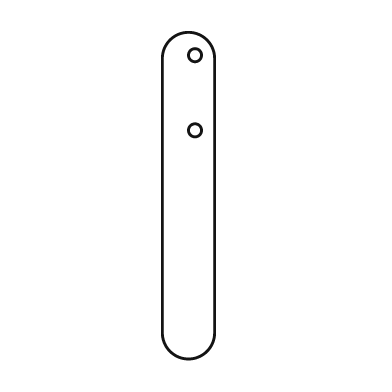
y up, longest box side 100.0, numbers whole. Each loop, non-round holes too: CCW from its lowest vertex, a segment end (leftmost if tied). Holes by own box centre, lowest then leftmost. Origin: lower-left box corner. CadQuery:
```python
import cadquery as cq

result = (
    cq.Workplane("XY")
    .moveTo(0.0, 8.0)
    .threePointArc((8.0, 0.0), (16.0, 8.0))
    .lineTo(16.0, 92.0)
    .threePointArc((8.0, 100.0), (0.0, 92.0))
    .close()
    .moveTo(10.0, 70.0)
    .circle(2.0)
    .moveTo(10.0, 93.0)
    .circle(2.0)
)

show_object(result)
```